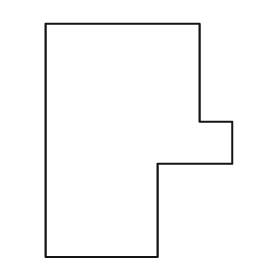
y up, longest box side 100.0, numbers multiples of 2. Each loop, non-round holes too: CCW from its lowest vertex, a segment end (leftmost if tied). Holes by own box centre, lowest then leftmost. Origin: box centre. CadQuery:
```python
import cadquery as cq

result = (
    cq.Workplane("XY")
    .moveTo(-40.0, -50.0)
    .lineTo(8.0, -50.0)
    .lineTo(8.0, -10.0)
    .lineTo(40.0, -10.0)
    .lineTo(40.0, 8.0)
    .lineTo(26.0, 8.0)
    .lineTo(26.0, 50.0)
    .lineTo(-40.0, 50.0)
    .close()
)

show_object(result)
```